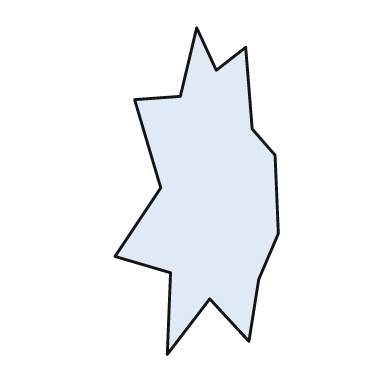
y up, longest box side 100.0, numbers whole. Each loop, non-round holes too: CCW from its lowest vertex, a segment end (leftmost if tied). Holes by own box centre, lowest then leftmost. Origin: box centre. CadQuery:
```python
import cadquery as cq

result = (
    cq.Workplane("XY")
    .moveTo(-9.0, -50.0)
    .lineTo(4.0, -33.0)
    .lineTo(16.0, -46.0)
    .lineTo(19.0, -27.0)
    .lineTo(25.0, -13.0)
    .lineTo(24.0, 11.0)
    .lineTo(17.0, 19.0)
    .lineTo(15.0, 44.0)
    .lineTo(6.0, 37.0)
    .lineTo(0.0, 50.0)
    .lineTo(-5.0, 29.0)
    .lineTo(-19.0, 28.0)
    .lineTo(-11.0, 1.0)
    .lineTo(-25.0, -20.0)
    .lineTo(-8.0, -25.0)
    .close()
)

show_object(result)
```